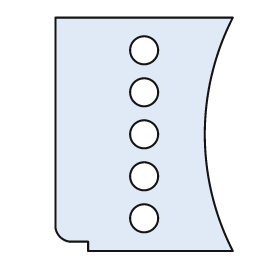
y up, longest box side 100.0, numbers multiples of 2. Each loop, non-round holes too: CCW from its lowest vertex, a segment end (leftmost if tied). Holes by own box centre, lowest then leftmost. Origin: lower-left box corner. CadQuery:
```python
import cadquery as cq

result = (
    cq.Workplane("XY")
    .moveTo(14.0, 0.0)
    .lineTo(76.0, 0.0)
    .threePointArc((64.0, 50.0), (76.0, 100.0))
    .lineTo(0.0, 100.0)
    .lineTo(0.0, 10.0)
    .threePointArc((2.0, 6.0), (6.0, 4.0))
    .lineTo(14.0, 4.0)
    .close()
    .moveTo(38.0, 14.0)
    .circle(6.0)
    .moveTo(38.0, 32.0)
    .circle(6.0)
    .moveTo(38.0, 50.0)
    .circle(6.0)
    .moveTo(38.0, 68.0)
    .circle(6.0)
    .moveTo(38.0, 86.0)
    .circle(6.0)
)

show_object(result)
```